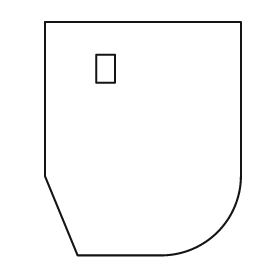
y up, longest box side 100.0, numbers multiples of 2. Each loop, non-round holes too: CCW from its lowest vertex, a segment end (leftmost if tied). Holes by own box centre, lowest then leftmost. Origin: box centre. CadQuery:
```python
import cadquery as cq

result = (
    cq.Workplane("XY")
    .moveTo(-28.0, -50.0)
    .lineTo(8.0, -50.0)
    .threePointArc((32.0, -40.0), (42.0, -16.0))
    .lineTo(42.0, 50.0)
    .lineTo(-42.0, 50.0)
    .lineTo(-42.0, -16.0)
    .close()
    .moveTo(-20.0, 24.0)
    .lineTo(-12.0, 24.0)
    .lineTo(-12.0, 36.0)
    .lineTo(-20.0, 36.0)
    .close()
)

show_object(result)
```